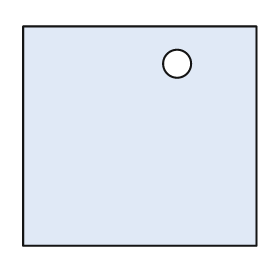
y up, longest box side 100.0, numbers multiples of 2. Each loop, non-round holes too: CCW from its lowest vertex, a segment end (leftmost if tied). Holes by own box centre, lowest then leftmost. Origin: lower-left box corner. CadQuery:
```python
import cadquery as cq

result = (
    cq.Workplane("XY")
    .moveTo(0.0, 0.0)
    .lineTo(100.0, 0.0)
    .lineTo(100.0, 94.0)
    .lineTo(0.0, 94.0)
    .close()
    .moveTo(66.0, 78.0)
    .circle(6.0)
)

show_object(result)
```